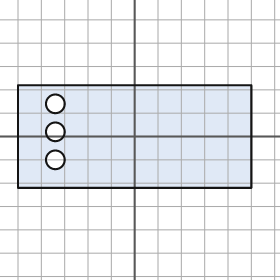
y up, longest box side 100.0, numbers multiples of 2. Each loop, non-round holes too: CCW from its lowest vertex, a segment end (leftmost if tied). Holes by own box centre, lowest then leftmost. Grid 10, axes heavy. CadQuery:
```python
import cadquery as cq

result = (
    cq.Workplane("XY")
    .moveTo(-50.0, -22.0)
    .lineTo(50.0, -22.0)
    .lineTo(50.0, 22.0)
    .lineTo(-50.0, 22.0)
    .close()
    .moveTo(-34.0, -10.0)
    .circle(4.0)
    .moveTo(-34.0, 2.0)
    .circle(4.0)
    .moveTo(-34.0, 14.0)
    .circle(4.0)
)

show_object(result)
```